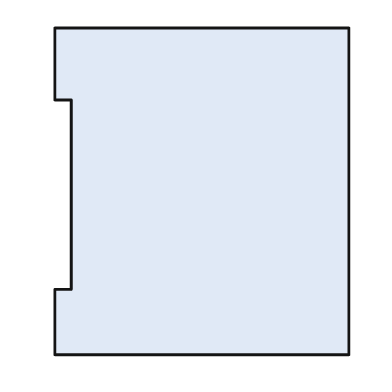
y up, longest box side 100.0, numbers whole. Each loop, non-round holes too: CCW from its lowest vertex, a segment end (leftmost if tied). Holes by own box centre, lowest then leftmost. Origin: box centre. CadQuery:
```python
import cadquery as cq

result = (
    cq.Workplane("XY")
    .moveTo(-45.0, -50.0)
    .lineTo(45.0, -50.0)
    .lineTo(45.0, 50.0)
    .lineTo(-45.0, 50.0)
    .lineTo(-45.0, 28.0)
    .lineTo(-40.0, 28.0)
    .lineTo(-40.0, -30.0)
    .lineTo(-45.0, -30.0)
    .close()
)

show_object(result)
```